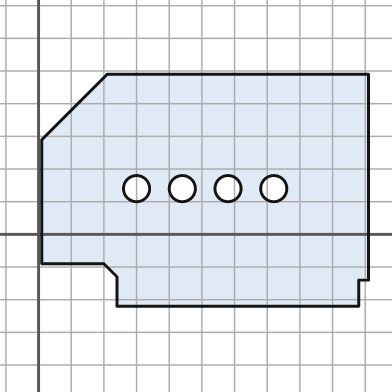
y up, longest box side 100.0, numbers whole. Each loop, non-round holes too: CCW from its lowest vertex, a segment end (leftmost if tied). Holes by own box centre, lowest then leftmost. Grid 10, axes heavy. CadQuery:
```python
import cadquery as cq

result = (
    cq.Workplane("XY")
    .moveTo(24.0, -22.0)
    .lineTo(98.0, -22.0)
    .lineTo(98.0, -14.0)
    .lineTo(101.0, -14.0)
    .lineTo(101.0, 49.0)
    .lineTo(21.0, 49.0)
    .lineTo(1.0, 29.0)
    .lineTo(1.0, -9.0)
    .lineTo(20.0, -9.0)
    .lineTo(24.0, -13.0)
    .close()
    .moveTo(30.0, 14.0)
    .circle(4.0)
    .moveTo(44.0, 14.0)
    .circle(4.0)
    .moveTo(58.0, 14.0)
    .circle(4.0)
    .moveTo(72.0, 14.0)
    .circle(4.0)
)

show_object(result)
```